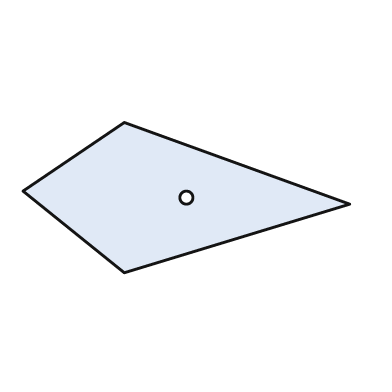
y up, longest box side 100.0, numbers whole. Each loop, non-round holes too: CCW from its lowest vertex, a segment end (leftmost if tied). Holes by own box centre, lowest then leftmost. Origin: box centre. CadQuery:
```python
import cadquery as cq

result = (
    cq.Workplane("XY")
    .moveTo(-19.0, -23.0)
    .lineTo(50.0, -2.0)
    .lineTo(-19.0, 23.0)
    .lineTo(-50.0, 2.0)
    .close()
    .moveTo(0.0, 0.0)
    .circle(2.0)
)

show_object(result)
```